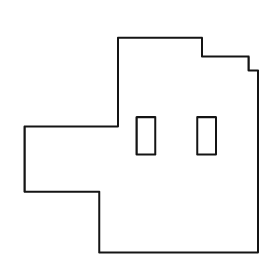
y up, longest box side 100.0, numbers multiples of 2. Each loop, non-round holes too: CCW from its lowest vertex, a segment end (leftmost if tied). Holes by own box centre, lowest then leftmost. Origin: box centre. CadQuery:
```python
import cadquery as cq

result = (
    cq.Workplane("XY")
    .moveTo(-18.0, -46.0)
    .lineTo(50.0, -46.0)
    .lineTo(50.0, 32.0)
    .lineTo(46.0, 32.0)
    .lineTo(46.0, 38.0)
    .lineTo(26.0, 38.0)
    .lineTo(26.0, 46.0)
    .lineTo(-10.0, 46.0)
    .lineTo(-10.0, 8.0)
    .lineTo(-50.0, 8.0)
    .lineTo(-50.0, -20.0)
    .lineTo(-18.0, -20.0)
    .close()
    .moveTo(-2.0, -4.0)
    .lineTo(6.0, -4.0)
    .lineTo(6.0, 12.0)
    .lineTo(-2.0, 12.0)
    .close()
    .moveTo(24.0, -4.0)
    .lineTo(32.0, -4.0)
    .lineTo(32.0, 12.0)
    .lineTo(24.0, 12.0)
    .close()
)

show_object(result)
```